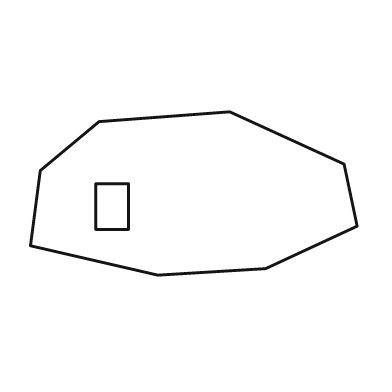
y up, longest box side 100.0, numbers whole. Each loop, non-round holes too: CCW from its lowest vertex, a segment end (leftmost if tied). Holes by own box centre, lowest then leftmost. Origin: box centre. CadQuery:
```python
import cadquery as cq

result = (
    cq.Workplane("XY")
    .moveTo(-11.0, -25.0)
    .lineTo(22.0, -23.0)
    .lineTo(50.0, -10.0)
    .lineTo(46.0, 9.0)
    .lineTo(11.0, 25.0)
    .lineTo(-29.0, 22.0)
    .lineTo(-47.0, 7.0)
    .lineTo(-50.0, -16.0)
    .close()
    .moveTo(-30.0, -11.0)
    .lineTo(-20.0, -11.0)
    .lineTo(-20.0, 3.0)
    .lineTo(-30.0, 3.0)
    .close()
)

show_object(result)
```